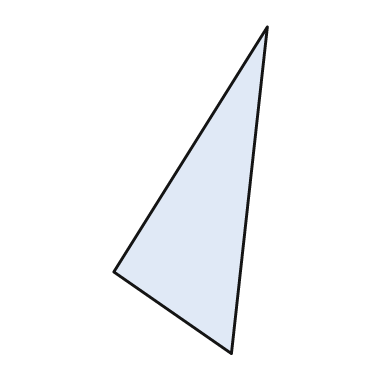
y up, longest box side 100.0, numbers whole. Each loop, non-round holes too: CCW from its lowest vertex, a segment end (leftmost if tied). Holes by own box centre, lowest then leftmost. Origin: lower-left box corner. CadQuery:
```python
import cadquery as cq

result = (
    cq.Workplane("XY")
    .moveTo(36.0, 0.0)
    .lineTo(47.0, 100.0)
    .lineTo(0.0, 25.0)
    .close()
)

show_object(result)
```